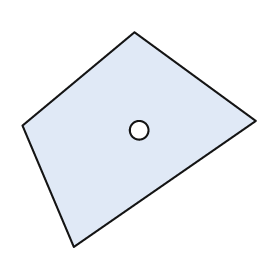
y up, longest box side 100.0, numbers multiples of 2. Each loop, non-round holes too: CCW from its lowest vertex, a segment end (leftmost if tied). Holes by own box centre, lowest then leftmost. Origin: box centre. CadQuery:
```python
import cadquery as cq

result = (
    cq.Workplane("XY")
    .moveTo(-28.0, -46.0)
    .lineTo(50.0, 8.0)
    .lineTo(-2.0, 46.0)
    .lineTo(-50.0, 6.0)
    .close()
    .moveTo(0.0, 4.0)
    .circle(4.0)
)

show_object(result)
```